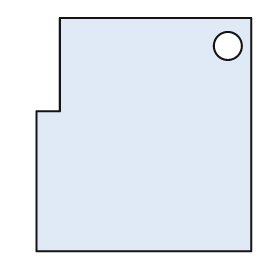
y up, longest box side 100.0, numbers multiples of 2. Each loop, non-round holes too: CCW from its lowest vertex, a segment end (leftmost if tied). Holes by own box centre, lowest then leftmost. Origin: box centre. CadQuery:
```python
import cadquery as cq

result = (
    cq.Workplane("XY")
    .moveTo(-46.0, -50.0)
    .lineTo(46.0, -50.0)
    .lineTo(46.0, 50.0)
    .lineTo(-36.0, 50.0)
    .lineTo(-36.0, 10.0)
    .lineTo(-46.0, 10.0)
    .close()
    .moveTo(36.0, 38.0)
    .circle(6.0)
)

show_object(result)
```